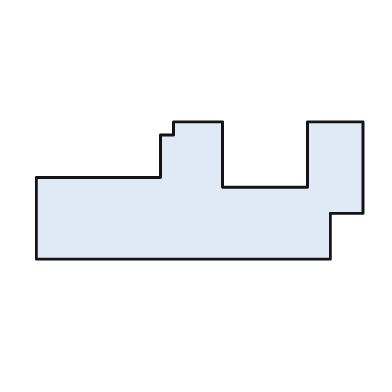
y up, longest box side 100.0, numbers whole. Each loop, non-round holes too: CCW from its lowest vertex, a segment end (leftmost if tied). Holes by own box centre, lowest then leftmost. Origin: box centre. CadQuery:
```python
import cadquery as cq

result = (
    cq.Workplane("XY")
    .moveTo(-50.0, -21.0)
    .lineTo(40.0, -21.0)
    .lineTo(40.0, -7.0)
    .lineTo(50.0, -7.0)
    .lineTo(50.0, 21.0)
    .lineTo(33.0, 21.0)
    .lineTo(33.0, 1.0)
    .lineTo(7.0, 1.0)
    .lineTo(7.0, 21.0)
    .lineTo(-8.0, 21.0)
    .lineTo(-8.0, 17.0)
    .lineTo(-12.0, 17.0)
    .lineTo(-12.0, 4.0)
    .lineTo(-50.0, 4.0)
    .close()
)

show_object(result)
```